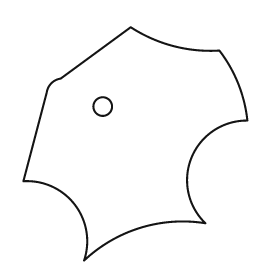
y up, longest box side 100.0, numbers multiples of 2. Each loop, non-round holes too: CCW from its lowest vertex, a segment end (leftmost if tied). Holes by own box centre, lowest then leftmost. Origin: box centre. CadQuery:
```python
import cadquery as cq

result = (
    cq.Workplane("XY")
    .moveTo(-22.0, -50.0)
    .threePointArc((2.0, -36.0), (30.0, -34.0))
    .threePointArc((24.0, -6.0), (48.0, 10.0))
    .threePointArc((44.0, 26.0), (36.0, 40.0))
    .threePointArc((16.0, 42.0), (-2.0, 50.0))
    .lineTo(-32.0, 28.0)
    .threePointArc((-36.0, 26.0), (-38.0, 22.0))
    .lineTo(-48.0, -16.0)
    .threePointArc((-26.0, -26.0), (-22.0, -50.0))
    .close()
    .moveTo(-14.0, 16.0)
    .circle(4.0)
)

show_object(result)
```